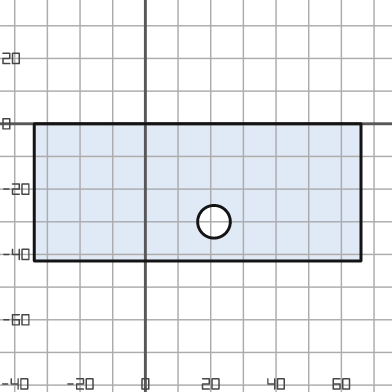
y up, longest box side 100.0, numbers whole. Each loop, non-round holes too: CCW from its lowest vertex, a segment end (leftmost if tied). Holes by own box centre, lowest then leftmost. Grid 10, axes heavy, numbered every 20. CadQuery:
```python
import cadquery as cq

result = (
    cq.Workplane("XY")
    .moveTo(-34.0, -42.0)
    .lineTo(66.0, -42.0)
    .lineTo(66.0, 0.0)
    .lineTo(-34.0, 0.0)
    .close()
    .moveTo(21.0, -30.0)
    .circle(5.0)
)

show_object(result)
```